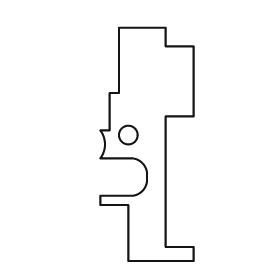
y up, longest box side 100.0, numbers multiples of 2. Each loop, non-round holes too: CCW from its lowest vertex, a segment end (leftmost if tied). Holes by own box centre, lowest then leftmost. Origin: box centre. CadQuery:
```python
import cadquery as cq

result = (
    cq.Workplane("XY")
    .moveTo(-8.0, -50.0)
    .lineTo(20.0, -50.0)
    .lineTo(20.0, -44.0)
    .lineTo(8.0, -44.0)
    .lineTo(8.0, 12.0)
    .lineTo(20.0, 12.0)
    .lineTo(20.0, 42.0)
    .lineTo(8.0, 42.0)
    .lineTo(8.0, 50.0)
    .lineTo(-12.0, 50.0)
    .lineTo(-12.0, 22.0)
    .lineTo(-16.0, 22.0)
    .lineTo(-16.0, 6.0)
    .lineTo(-20.0, 6.0)
    .threePointArc((-18.0, 0.0), (-20.0, -6.0))
    .lineTo(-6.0, -6.0)
    .threePointArc((-2.0, -8.0), (0.0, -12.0))
    .lineTo(0.0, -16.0)
    .threePointArc((-2.0, -20.0), (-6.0, -22.0))
    .lineTo(-20.0, -22.0)
    .lineTo(-20.0, -26.0)
    .lineTo(-8.0, -26.0)
    .close()
    .moveTo(-8.0, 4.0)
    .circle(4.0)
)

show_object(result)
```